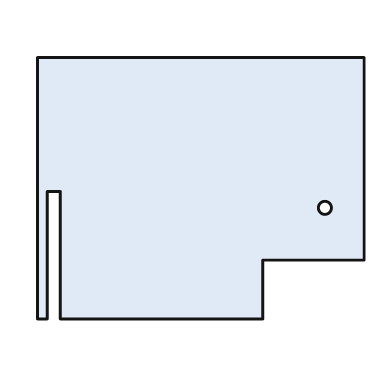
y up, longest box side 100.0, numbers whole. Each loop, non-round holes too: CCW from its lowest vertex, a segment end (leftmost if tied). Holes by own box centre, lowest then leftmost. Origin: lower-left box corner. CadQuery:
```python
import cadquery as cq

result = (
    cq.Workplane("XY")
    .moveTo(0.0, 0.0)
    .lineTo(3.0, 0.0)
    .lineTo(3.0, 39.0)
    .lineTo(7.0, 39.0)
    .lineTo(7.0, 0.0)
    .lineTo(69.0, 0.0)
    .lineTo(69.0, 18.0)
    .lineTo(100.0, 18.0)
    .lineTo(100.0, 80.0)
    .lineTo(0.0, 80.0)
    .close()
    .moveTo(88.0, 34.0)
    .circle(2.0)
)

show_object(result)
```